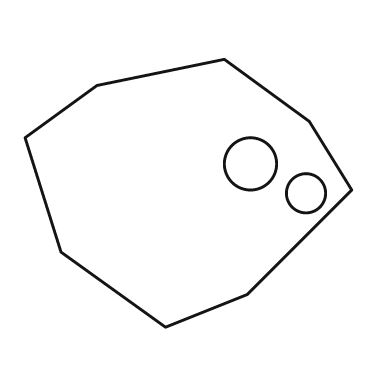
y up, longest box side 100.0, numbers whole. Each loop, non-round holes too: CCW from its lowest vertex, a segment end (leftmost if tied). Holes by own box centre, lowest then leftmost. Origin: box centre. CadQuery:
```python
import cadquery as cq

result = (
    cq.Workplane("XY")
    .moveTo(-7.0, -41.0)
    .lineTo(18.0, -31.0)
    .lineTo(50.0, 1.0)
    .lineTo(37.0, 22.0)
    .lineTo(11.0, 41.0)
    .lineTo(-28.0, 33.0)
    .lineTo(-50.0, 17.0)
    .lineTo(-39.0, -18.0)
    .close()
    .moveTo(36.0, 0.0)
    .circle(6.0)
    .moveTo(19.0, 9.0)
    .circle(8.0)
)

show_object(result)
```